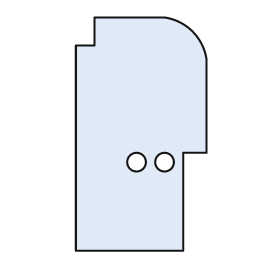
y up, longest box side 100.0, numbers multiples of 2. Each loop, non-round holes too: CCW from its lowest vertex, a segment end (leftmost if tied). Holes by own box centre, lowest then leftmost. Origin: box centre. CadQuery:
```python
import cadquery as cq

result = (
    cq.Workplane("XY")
    .moveTo(-28.0, -50.0)
    .lineTo(18.0, -50.0)
    .lineTo(18.0, -8.0)
    .lineTo(28.0, -8.0)
    .lineTo(28.0, 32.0)
    .threePointArc((22.0, 44.0), (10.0, 50.0))
    .lineTo(-20.0, 50.0)
    .lineTo(-20.0, 38.0)
    .lineTo(-28.0, 38.0)
    .close()
    .moveTo(-2.0, -12.0)
    .circle(4.0)
    .moveTo(10.0, -12.0)
    .circle(4.0)
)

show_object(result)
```